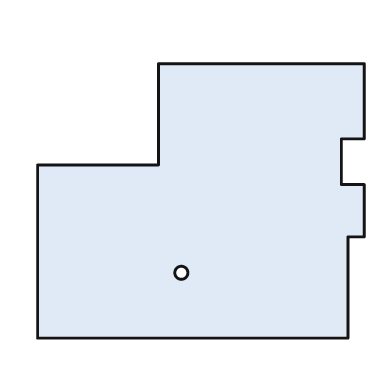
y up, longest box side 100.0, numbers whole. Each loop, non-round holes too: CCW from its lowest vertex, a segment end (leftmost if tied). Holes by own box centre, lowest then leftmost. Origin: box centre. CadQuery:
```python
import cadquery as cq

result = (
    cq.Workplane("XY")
    .moveTo(-50.0, -42.0)
    .lineTo(45.0, -42.0)
    .lineTo(45.0, -11.0)
    .lineTo(50.0, -11.0)
    .lineTo(50.0, 5.0)
    .lineTo(43.0, 5.0)
    .lineTo(43.0, 19.0)
    .lineTo(50.0, 19.0)
    .lineTo(50.0, 42.0)
    .lineTo(-13.0, 42.0)
    .lineTo(-13.0, 11.0)
    .lineTo(-50.0, 11.0)
    .close()
    .moveTo(-6.0, -22.0)
    .circle(2.0)
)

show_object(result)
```